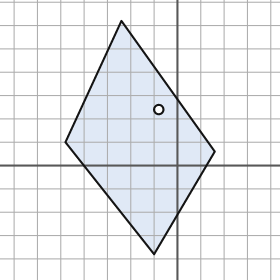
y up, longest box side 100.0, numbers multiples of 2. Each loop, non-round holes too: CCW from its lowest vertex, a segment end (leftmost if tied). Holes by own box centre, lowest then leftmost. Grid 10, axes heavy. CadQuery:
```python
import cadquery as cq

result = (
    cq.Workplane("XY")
    .moveTo(-10.0, -38.0)
    .lineTo(16.0, 6.0)
    .lineTo(-24.0, 62.0)
    .lineTo(-48.0, 10.0)
    .close()
    .moveTo(-8.0, 24.0)
    .circle(2.0)
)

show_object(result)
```